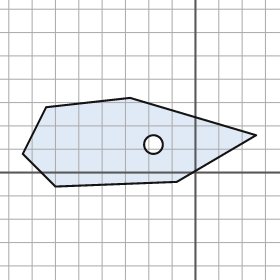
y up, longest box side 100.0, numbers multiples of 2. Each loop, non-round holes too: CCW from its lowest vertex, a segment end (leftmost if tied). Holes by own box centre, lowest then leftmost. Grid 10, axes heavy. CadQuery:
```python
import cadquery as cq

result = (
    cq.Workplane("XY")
    .moveTo(-60.0, -6.0)
    .lineTo(-8.0, -4.0)
    .lineTo(26.0, 16.0)
    .lineTo(-28.0, 32.0)
    .lineTo(-64.0, 28.0)
    .lineTo(-74.0, 8.0)
    .close()
    .moveTo(-18.0, 12.0)
    .circle(4.0)
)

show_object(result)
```